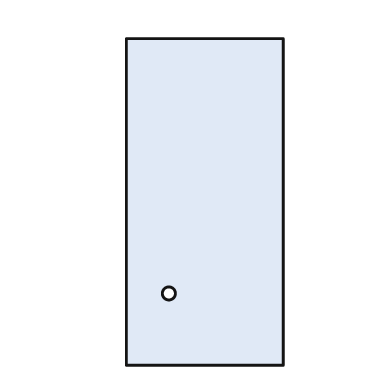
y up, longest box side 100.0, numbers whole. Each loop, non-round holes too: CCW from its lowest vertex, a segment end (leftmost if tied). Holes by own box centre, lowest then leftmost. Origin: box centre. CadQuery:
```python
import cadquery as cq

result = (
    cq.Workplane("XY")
    .moveTo(-24.0, -50.0)
    .lineTo(24.0, -50.0)
    .lineTo(24.0, 50.0)
    .lineTo(-24.0, 50.0)
    .close()
    .moveTo(-11.0, -28.0)
    .circle(2.0)
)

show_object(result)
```